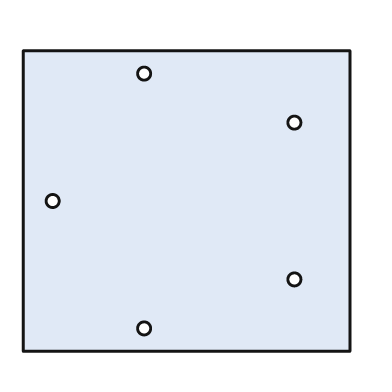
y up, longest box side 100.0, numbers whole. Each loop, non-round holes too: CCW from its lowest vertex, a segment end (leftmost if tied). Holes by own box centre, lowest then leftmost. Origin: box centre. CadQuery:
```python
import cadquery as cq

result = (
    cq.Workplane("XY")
    .moveTo(-50.0, -46.0)
    .lineTo(50.0, -46.0)
    .lineTo(50.0, 46.0)
    .lineTo(-50.0, 46.0)
    .close()
    .moveTo(-13.0, -39.0)
    .circle(2.0)
    .moveTo(33.0, -24.0)
    .circle(2.0)
    .moveTo(-41.0, 0.0)
    .circle(2.0)
    .moveTo(33.0, 24.0)
    .circle(2.0)
    .moveTo(-13.0, 39.0)
    .circle(2.0)
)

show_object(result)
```